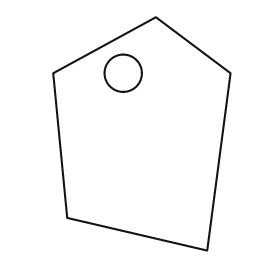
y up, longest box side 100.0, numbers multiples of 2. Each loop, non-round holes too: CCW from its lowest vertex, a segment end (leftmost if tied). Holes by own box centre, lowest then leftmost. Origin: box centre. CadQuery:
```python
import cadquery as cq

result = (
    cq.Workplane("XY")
    .moveTo(28.0, -50.0)
    .lineTo(38.0, 26.0)
    .lineTo(6.0, 50.0)
    .lineTo(-38.0, 26.0)
    .lineTo(-32.0, -36.0)
    .close()
    .moveTo(-8.0, 26.0)
    .circle(8.0)
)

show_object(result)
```